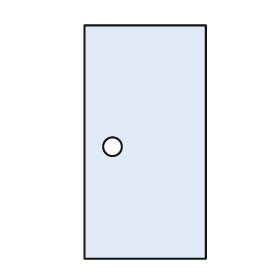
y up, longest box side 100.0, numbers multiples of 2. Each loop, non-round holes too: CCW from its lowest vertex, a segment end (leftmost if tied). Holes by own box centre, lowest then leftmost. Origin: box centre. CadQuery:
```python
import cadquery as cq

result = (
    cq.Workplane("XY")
    .moveTo(-26.0, -50.0)
    .lineTo(26.0, -50.0)
    .lineTo(26.0, 50.0)
    .lineTo(-26.0, 50.0)
    .close()
    .moveTo(-14.0, -2.0)
    .circle(4.0)
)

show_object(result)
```